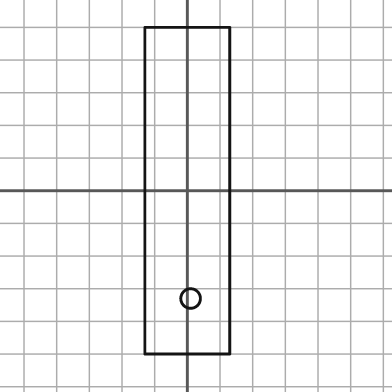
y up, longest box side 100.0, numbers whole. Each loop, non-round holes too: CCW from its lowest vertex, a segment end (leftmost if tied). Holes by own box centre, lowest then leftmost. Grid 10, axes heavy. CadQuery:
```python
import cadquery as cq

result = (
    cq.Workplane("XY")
    .moveTo(-13.0, -50.0)
    .lineTo(13.0, -50.0)
    .lineTo(13.0, 50.0)
    .lineTo(-13.0, 50.0)
    .close()
    .moveTo(1.0, -33.0)
    .circle(3.0)
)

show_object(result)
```